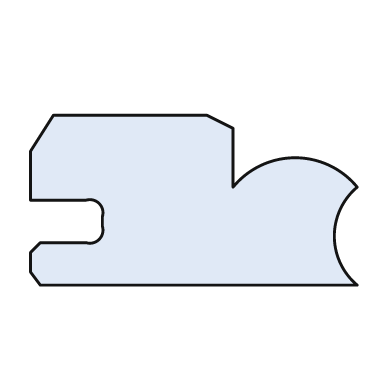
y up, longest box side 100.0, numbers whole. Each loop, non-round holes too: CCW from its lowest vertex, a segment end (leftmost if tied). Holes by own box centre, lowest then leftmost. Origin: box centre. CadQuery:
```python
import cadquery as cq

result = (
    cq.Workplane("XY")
    .moveTo(-47.0, -26.0)
    .lineTo(50.0, -26.0)
    .threePointArc((43.0, -11.0), (50.0, 4.0))
    .threePointArc((31.0, 13.0), (12.0, 4.0))
    .lineTo(12.0, 22.0)
    .lineTo(4.0, 26.0)
    .lineTo(-43.0, 26.0)
    .lineTo(-50.0, 15.0)
    .lineTo(-50.0, 0.0)
    .lineTo(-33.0, 0.0)
    .threePointArc((-29.0, -1.0), (-28.0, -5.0))
    .lineTo(-28.0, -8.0)
    .threePointArc((-29.0, -12.0), (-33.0, -13.0))
    .lineTo(-47.0, -13.0)
    .lineTo(-50.0, -16.0)
    .lineTo(-50.0, -22.0)
    .close()
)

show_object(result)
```